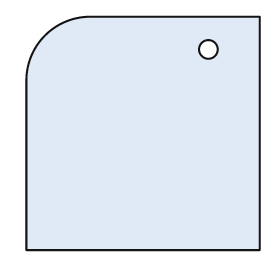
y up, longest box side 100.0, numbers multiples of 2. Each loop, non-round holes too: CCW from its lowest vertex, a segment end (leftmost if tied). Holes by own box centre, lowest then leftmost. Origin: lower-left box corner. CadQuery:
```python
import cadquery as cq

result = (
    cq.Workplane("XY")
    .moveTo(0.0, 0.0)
    .lineTo(100.0, 0.0)
    .lineTo(100.0, 100.0)
    .lineTo(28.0, 100.0)
    .threePointArc((8.0, 92.0), (0.0, 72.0))
    .close()
    .moveTo(78.0, 86.0)
    .circle(4.0)
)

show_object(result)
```